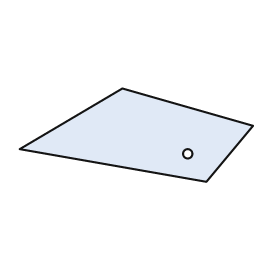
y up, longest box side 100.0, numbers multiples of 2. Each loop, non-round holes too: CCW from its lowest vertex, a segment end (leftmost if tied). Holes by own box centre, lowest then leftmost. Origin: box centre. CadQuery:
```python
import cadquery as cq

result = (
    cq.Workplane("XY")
    .moveTo(30.0, -20.0)
    .lineTo(50.0, 4.0)
    .lineTo(-6.0, 20.0)
    .lineTo(-50.0, -6.0)
    .close()
    .moveTo(22.0, -8.0)
    .circle(2.0)
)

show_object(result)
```